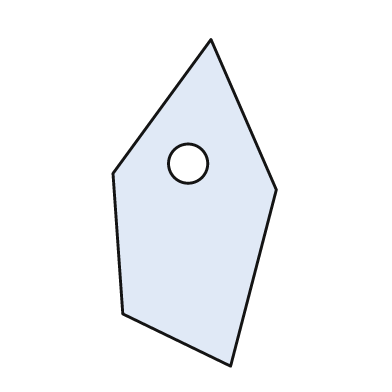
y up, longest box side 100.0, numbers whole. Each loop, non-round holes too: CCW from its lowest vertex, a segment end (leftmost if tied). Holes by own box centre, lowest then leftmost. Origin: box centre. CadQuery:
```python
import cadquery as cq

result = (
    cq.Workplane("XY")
    .moveTo(11.0, -50.0)
    .lineTo(25.0, 4.0)
    .lineTo(5.0, 50.0)
    .lineTo(-25.0, 9.0)
    .lineTo(-22.0, -34.0)
    .close()
    .moveTo(-2.0, 12.0)
    .circle(6.0)
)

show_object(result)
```